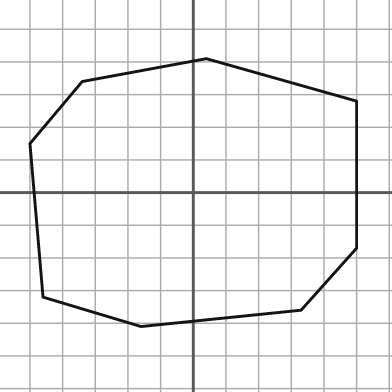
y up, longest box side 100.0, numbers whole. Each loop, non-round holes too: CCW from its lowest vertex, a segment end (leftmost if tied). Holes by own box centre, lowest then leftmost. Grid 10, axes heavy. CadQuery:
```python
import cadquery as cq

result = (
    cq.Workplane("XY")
    .moveTo(-16.0, -41.0)
    .lineTo(33.0, -36.0)
    .lineTo(50.0, -17.0)
    .lineTo(50.0, 28.0)
    .lineTo(4.0, 41.0)
    .lineTo(-34.0, 34.0)
    .lineTo(-50.0, 15.0)
    .lineTo(-46.0, -32.0)
    .close()
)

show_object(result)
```